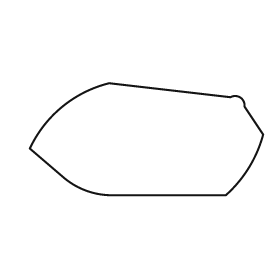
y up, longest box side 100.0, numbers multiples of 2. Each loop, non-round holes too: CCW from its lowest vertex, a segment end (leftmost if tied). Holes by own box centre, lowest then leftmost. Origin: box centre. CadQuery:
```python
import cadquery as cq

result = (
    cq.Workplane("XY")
    .moveTo(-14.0, -24.0)
    .lineTo(34.0, -24.0)
    .threePointArc((44.0, -12.0), (50.0, 2.0))
    .lineTo(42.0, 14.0)
    .threePointArc((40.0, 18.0), (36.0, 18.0))
    .lineTo(-16.0, 24.0)
    .threePointArc((-36.0, 14.0), (-50.0, -4.0))
    .lineTo(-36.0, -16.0)
    .threePointArc((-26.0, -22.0), (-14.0, -24.0))
    .close()
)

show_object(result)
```